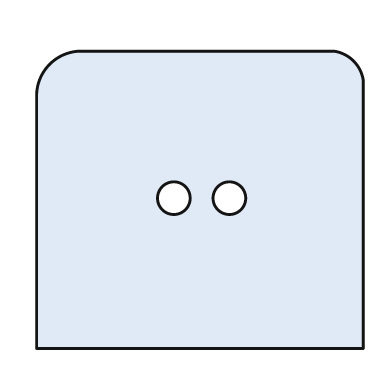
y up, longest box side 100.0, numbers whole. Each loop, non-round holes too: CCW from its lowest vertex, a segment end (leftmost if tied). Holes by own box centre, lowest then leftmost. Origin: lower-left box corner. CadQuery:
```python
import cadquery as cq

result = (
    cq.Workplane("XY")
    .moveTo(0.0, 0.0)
    .lineTo(100.0, 0.0)
    .lineTo(100.0, 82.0)
    .threePointArc((97.0, 88.0), (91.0, 91.0))
    .lineTo(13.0, 91.0)
    .threePointArc((4.0, 87.0), (0.0, 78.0))
    .close()
    .moveTo(42.0, 46.0)
    .circle(5.0)
    .moveTo(59.0, 46.0)
    .circle(5.0)
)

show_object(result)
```